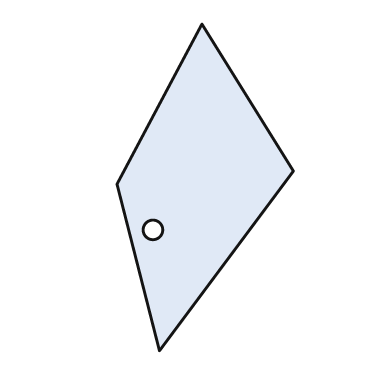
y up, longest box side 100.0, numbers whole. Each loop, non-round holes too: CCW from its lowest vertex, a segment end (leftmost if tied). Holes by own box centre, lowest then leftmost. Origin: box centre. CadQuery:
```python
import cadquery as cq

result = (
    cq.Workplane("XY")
    .moveTo(-14.0, -50.0)
    .lineTo(27.0, 5.0)
    .lineTo(-1.0, 50.0)
    .lineTo(-27.0, 1.0)
    .close()
    .moveTo(-16.0, -13.0)
    .circle(3.0)
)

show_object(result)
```